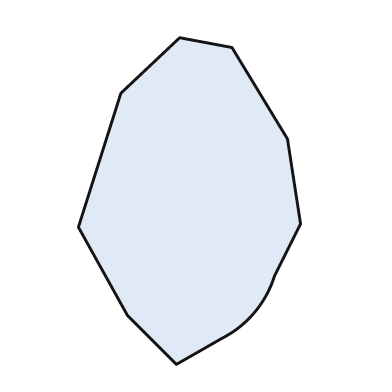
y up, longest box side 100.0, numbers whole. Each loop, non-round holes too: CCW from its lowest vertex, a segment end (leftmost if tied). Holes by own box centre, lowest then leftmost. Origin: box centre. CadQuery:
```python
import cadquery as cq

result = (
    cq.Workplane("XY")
    .moveTo(-4.0, -50.0)
    .lineTo(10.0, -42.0)
    .threePointArc((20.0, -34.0), (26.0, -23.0))
    .lineTo(34.0, -7.0)
    .lineTo(30.0, 19.0)
    .lineTo(13.0, 47.0)
    .lineTo(-3.0, 50.0)
    .lineTo(-21.0, 33.0)
    .lineTo(-34.0, -8.0)
    .lineTo(-19.0, -35.0)
    .close()
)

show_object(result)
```